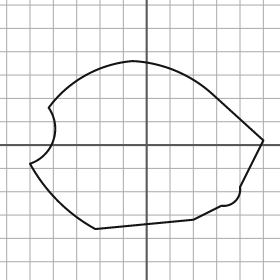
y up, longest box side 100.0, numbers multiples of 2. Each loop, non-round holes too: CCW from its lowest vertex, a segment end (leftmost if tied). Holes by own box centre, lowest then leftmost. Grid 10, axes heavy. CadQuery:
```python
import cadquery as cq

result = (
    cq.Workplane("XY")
    .moveTo(-22.0, -36.0)
    .lineTo(20.0, -32.0)
    .lineTo(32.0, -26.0)
    .threePointArc((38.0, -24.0), (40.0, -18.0))
    .lineTo(50.0, 2.0)
    .lineTo(28.0, 22.0)
    .threePointArc((12.0, 32.0), (-6.0, 36.0))
    .threePointArc((-26.0, 30.0), (-42.0, 16.0))
    .threePointArc((-40.0, 2.0), (-50.0, -8.0))
    .threePointArc((-38.0, -24.0), (-22.0, -36.0))
    .close()
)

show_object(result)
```